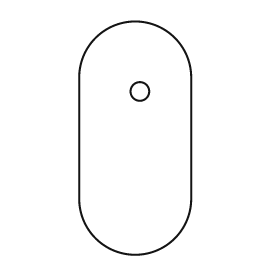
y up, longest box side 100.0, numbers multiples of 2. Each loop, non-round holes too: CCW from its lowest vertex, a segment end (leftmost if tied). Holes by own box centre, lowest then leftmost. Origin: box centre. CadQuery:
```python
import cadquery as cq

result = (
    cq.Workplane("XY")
    .moveTo(-24.0, -26.0)
    .threePointArc((0.0, -50.0), (24.0, -26.0))
    .lineTo(24.0, 26.0)
    .threePointArc((0.0, 50.0), (-24.0, 26.0))
    .close()
    .moveTo(2.0, 20.0)
    .circle(4.0)
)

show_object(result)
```